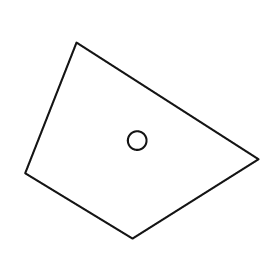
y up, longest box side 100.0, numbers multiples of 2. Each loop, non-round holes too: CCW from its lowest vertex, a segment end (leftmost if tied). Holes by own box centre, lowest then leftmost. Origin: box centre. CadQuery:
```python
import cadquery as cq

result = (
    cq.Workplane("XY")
    .moveTo(-4.0, -42.0)
    .lineTo(50.0, -8.0)
    .lineTo(-28.0, 42.0)
    .lineTo(-50.0, -14.0)
    .close()
    .moveTo(-2.0, 0.0)
    .circle(4.0)
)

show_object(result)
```